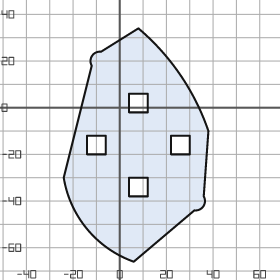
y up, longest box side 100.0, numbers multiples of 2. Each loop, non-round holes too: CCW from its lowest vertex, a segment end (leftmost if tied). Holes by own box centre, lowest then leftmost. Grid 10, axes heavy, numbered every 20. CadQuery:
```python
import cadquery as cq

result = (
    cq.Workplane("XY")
    .moveTo(6.0, -66.0)
    .lineTo(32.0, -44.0)
    .threePointArc((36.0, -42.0), (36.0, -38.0))
    .lineTo(38.0, -10.0)
    .threePointArc((26.0, 14.0), (8.0, 34.0))
    .lineTo(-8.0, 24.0)
    .threePointArc((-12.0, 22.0), (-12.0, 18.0))
    .lineTo(-24.0, -30.0)
    .threePointArc((-14.0, -52.0), (6.0, -66.0))
    .close()
    .moveTo(4.0, -38.0)
    .lineTo(12.0, -38.0)
    .lineTo(12.0, -30.0)
    .lineTo(4.0, -30.0)
    .close()
    .moveTo(-14.0, -20.0)
    .lineTo(-6.0, -20.0)
    .lineTo(-6.0, -12.0)
    .lineTo(-14.0, -12.0)
    .close()
    .moveTo(22.0, -20.0)
    .lineTo(30.0, -20.0)
    .lineTo(30.0, -12.0)
    .lineTo(22.0, -12.0)
    .close()
    .moveTo(4.0, -2.0)
    .lineTo(12.0, -2.0)
    .lineTo(12.0, 6.0)
    .lineTo(4.0, 6.0)
    .close()
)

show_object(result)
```